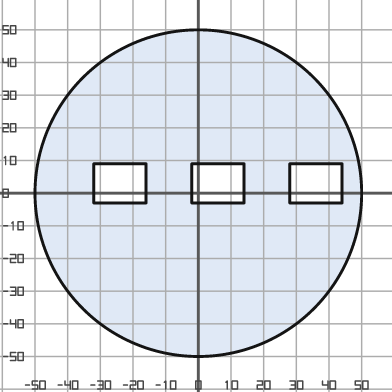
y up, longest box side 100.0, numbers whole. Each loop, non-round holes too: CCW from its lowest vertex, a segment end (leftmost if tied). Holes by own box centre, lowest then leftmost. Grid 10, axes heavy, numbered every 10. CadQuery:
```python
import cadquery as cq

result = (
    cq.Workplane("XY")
    .moveTo(0.0, 0.0)
    .circle(50.0)
    .moveTo(-32.0, -3.0)
    .lineTo(-16.0, -3.0)
    .lineTo(-16.0, 9.0)
    .lineTo(-32.0, 9.0)
    .close()
    .moveTo(-2.0, -3.0)
    .lineTo(14.0, -3.0)
    .lineTo(14.0, 9.0)
    .lineTo(-2.0, 9.0)
    .close()
    .moveTo(28.0, -3.0)
    .lineTo(44.0, -3.0)
    .lineTo(44.0, 9.0)
    .lineTo(28.0, 9.0)
    .close()
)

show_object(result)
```